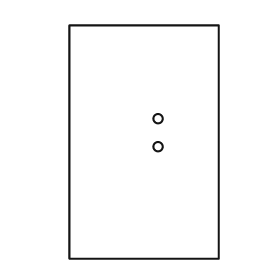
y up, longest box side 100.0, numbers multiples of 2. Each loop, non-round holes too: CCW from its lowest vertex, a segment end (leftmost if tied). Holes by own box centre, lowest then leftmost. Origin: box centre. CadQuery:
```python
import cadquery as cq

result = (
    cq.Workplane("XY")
    .moveTo(-32.0, -50.0)
    .lineTo(32.0, -50.0)
    .lineTo(32.0, 50.0)
    .lineTo(-32.0, 50.0)
    .close()
    .moveTo(6.0, -2.0)
    .circle(2.0)
    .moveTo(6.0, 10.0)
    .circle(2.0)
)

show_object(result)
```